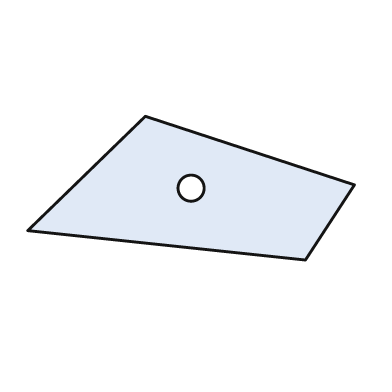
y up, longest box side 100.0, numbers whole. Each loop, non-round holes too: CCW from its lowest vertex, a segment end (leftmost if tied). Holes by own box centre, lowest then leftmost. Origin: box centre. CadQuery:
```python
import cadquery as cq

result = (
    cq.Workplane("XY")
    .moveTo(35.0, -22.0)
    .lineTo(50.0, 1.0)
    .lineTo(-14.0, 22.0)
    .lineTo(-50.0, -13.0)
    .close()
    .moveTo(0.0, 0.0)
    .circle(4.0)
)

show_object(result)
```